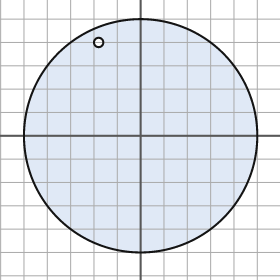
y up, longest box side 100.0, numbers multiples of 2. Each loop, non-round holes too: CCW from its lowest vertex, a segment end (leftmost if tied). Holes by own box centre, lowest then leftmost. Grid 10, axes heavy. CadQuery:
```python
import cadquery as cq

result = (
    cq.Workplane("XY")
    .moveTo(0.0, 0.0)
    .circle(50.0)
    .moveTo(-18.0, 40.0)
    .circle(2.0)
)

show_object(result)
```